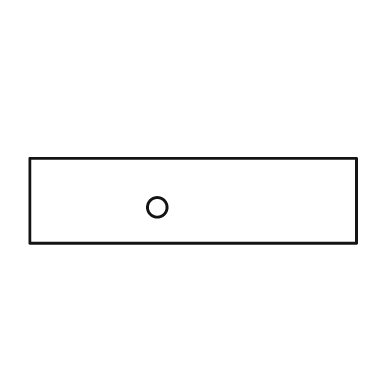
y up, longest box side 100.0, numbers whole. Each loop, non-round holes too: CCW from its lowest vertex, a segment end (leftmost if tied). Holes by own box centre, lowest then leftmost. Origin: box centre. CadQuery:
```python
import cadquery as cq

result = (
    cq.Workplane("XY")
    .moveTo(-50.0, -13.0)
    .lineTo(50.0, -13.0)
    .lineTo(50.0, 13.0)
    .lineTo(-50.0, 13.0)
    .close()
    .moveTo(-11.0, -2.0)
    .circle(3.0)
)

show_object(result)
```